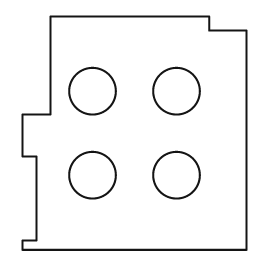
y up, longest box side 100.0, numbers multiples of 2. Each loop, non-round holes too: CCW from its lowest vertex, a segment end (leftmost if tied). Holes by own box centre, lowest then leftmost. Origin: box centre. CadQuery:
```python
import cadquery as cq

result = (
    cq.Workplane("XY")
    .moveTo(-48.0, -50.0)
    .lineTo(48.0, -50.0)
    .lineTo(48.0, 44.0)
    .lineTo(32.0, 44.0)
    .lineTo(32.0, 50.0)
    .lineTo(-36.0, 50.0)
    .lineTo(-36.0, 8.0)
    .lineTo(-48.0, 8.0)
    .lineTo(-48.0, -10.0)
    .lineTo(-42.0, -10.0)
    .lineTo(-42.0, -46.0)
    .lineTo(-48.0, -46.0)
    .close()
    .moveTo(-18.0, -18.0)
    .circle(10.0)
    .moveTo(18.0, -18.0)
    .circle(10.0)
    .moveTo(-18.0, 18.0)
    .circle(10.0)
    .moveTo(18.0, 18.0)
    .circle(10.0)
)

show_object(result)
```